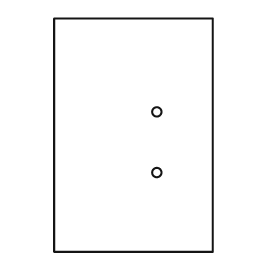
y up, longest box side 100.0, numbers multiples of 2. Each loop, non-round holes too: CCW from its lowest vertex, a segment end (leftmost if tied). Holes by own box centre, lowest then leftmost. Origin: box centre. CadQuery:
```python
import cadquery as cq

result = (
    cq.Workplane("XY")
    .moveTo(-34.0, -50.0)
    .lineTo(34.0, -50.0)
    .lineTo(34.0, 50.0)
    .lineTo(-34.0, 50.0)
    .close()
    .moveTo(10.0, -16.0)
    .circle(2.0)
    .moveTo(10.0, 10.0)
    .circle(2.0)
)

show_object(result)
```